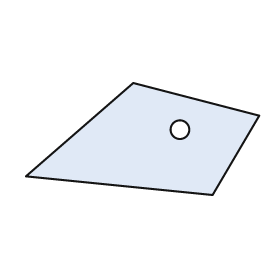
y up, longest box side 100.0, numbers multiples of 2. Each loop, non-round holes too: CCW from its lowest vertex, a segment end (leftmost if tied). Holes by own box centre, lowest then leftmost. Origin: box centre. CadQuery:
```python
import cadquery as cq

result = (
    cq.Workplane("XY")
    .moveTo(30.0, -24.0)
    .lineTo(50.0, 10.0)
    .lineTo(-4.0, 24.0)
    .lineTo(-50.0, -16.0)
    .close()
    .moveTo(16.0, 4.0)
    .circle(4.0)
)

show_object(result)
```